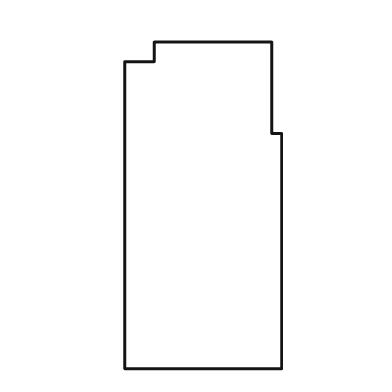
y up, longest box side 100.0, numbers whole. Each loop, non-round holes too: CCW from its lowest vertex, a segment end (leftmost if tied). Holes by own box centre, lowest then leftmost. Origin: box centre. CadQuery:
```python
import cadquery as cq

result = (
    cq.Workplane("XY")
    .moveTo(-24.0, -50.0)
    .lineTo(24.0, -50.0)
    .lineTo(24.0, 22.0)
    .lineTo(21.0, 22.0)
    .lineTo(21.0, 50.0)
    .lineTo(-15.0, 50.0)
    .lineTo(-15.0, 44.0)
    .lineTo(-24.0, 44.0)
    .close()
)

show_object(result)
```